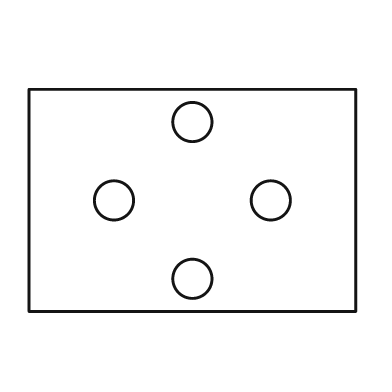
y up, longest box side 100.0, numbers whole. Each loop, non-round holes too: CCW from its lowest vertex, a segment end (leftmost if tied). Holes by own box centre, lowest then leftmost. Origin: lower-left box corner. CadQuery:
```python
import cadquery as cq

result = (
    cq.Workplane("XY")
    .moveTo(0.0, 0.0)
    .lineTo(100.0, 0.0)
    .lineTo(100.0, 68.0)
    .lineTo(0.0, 68.0)
    .close()
    .moveTo(50.0, 10.0)
    .circle(6.0)
    .moveTo(26.0, 34.0)
    .circle(6.0)
    .moveTo(74.0, 34.0)
    .circle(6.0)
    .moveTo(50.0, 58.0)
    .circle(6.0)
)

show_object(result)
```